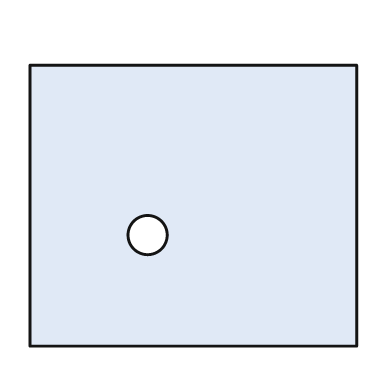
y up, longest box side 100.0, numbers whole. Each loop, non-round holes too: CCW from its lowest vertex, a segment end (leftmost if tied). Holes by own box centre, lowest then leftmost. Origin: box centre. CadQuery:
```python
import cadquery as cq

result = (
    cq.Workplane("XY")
    .moveTo(-50.0, -43.0)
    .lineTo(50.0, -43.0)
    .lineTo(50.0, 43.0)
    .lineTo(-50.0, 43.0)
    .close()
    .moveTo(-14.0, -9.0)
    .circle(6.0)
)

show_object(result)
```